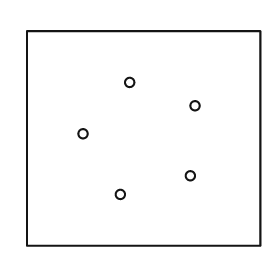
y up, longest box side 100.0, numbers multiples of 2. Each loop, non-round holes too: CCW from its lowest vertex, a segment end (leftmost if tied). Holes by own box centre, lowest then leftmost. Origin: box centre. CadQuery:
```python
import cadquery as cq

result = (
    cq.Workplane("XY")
    .moveTo(-50.0, -46.0)
    .lineTo(50.0, -46.0)
    .lineTo(50.0, 46.0)
    .lineTo(-50.0, 46.0)
    .close()
    .moveTo(-10.0, -24.0)
    .circle(2.0)
    .moveTo(20.0, -16.0)
    .circle(2.0)
    .moveTo(-26.0, 2.0)
    .circle(2.0)
    .moveTo(22.0, 14.0)
    .circle(2.0)
    .moveTo(-6.0, 24.0)
    .circle(2.0)
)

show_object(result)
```